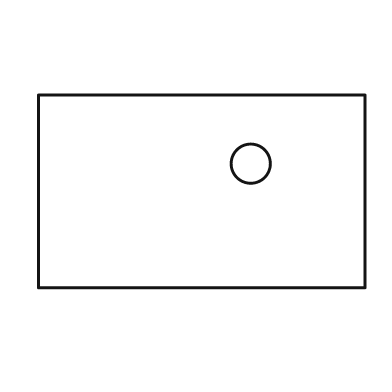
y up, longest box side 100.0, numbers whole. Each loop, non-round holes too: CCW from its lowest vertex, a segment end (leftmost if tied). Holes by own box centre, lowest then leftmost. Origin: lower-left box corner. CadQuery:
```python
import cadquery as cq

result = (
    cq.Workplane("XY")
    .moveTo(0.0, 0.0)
    .lineTo(100.0, 0.0)
    .lineTo(100.0, 59.0)
    .lineTo(0.0, 59.0)
    .close()
    .moveTo(65.0, 38.0)
    .circle(6.0)
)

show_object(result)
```